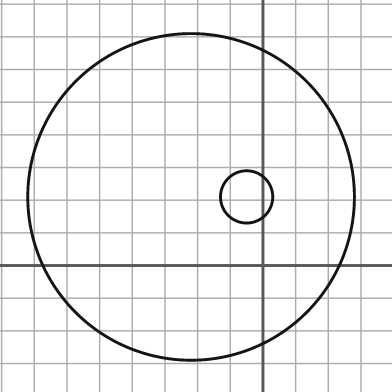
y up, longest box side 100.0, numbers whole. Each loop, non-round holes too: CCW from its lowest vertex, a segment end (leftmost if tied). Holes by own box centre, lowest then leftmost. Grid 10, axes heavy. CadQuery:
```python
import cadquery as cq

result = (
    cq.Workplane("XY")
    .moveTo(-22.0, 21.0)
    .circle(50.0)
    .moveTo(-5.0, 21.0)
    .circle(8.0)
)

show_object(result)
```